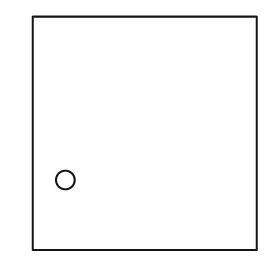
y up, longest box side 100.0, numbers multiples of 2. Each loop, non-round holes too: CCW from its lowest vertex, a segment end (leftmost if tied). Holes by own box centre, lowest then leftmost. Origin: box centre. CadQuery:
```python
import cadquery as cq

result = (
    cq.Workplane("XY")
    .moveTo(-48.0, -50.0)
    .lineTo(48.0, -50.0)
    .lineTo(48.0, 50.0)
    .lineTo(-48.0, 50.0)
    .close()
    .moveTo(-34.0, -20.0)
    .circle(4.0)
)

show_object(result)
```